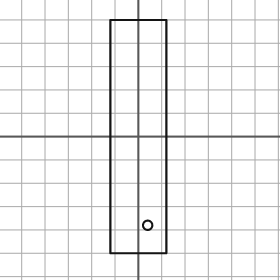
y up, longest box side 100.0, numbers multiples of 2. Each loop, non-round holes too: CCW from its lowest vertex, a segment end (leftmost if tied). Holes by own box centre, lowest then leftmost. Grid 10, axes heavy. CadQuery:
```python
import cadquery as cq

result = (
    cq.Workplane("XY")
    .moveTo(-12.0, -50.0)
    .lineTo(12.0, -50.0)
    .lineTo(12.0, 50.0)
    .lineTo(-12.0, 50.0)
    .close()
    .moveTo(4.0, -38.0)
    .circle(2.0)
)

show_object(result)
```